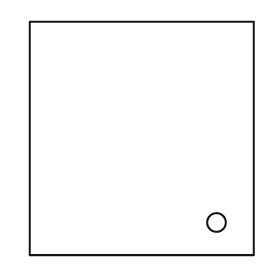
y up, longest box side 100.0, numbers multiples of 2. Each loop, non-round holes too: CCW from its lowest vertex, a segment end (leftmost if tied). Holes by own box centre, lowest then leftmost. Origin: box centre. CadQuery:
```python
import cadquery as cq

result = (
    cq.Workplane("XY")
    .moveTo(-48.0, -50.0)
    .lineTo(48.0, -50.0)
    .lineTo(48.0, 50.0)
    .lineTo(-48.0, 50.0)
    .close()
    .moveTo(32.0, -36.0)
    .circle(4.0)
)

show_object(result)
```